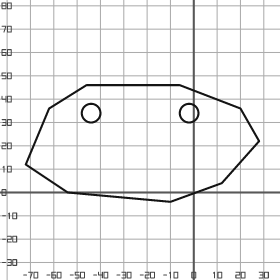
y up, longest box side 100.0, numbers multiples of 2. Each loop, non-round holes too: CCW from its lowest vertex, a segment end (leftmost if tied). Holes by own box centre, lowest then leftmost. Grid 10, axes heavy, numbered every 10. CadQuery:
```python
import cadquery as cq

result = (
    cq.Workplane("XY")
    .moveTo(-10.0, -4.0)
    .lineTo(12.0, 4.0)
    .lineTo(28.0, 22.0)
    .lineTo(20.0, 36.0)
    .lineTo(-6.0, 46.0)
    .lineTo(-46.0, 46.0)
    .lineTo(-62.0, 36.0)
    .lineTo(-72.0, 12.0)
    .lineTo(-54.0, 0.0)
    .close()
    .moveTo(-44.0, 34.0)
    .circle(4.0)
    .moveTo(-2.0, 34.0)
    .circle(4.0)
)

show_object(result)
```